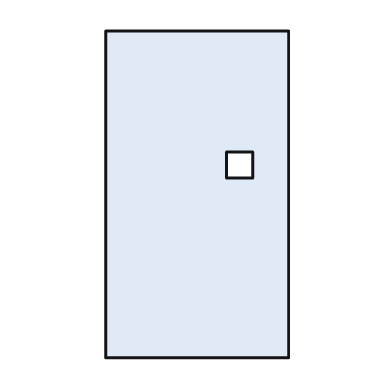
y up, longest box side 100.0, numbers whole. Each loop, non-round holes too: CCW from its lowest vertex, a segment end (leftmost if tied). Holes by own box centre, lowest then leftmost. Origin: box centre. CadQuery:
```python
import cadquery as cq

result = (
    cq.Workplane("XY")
    .moveTo(-28.0, -50.0)
    .lineTo(28.0, -50.0)
    .lineTo(28.0, 50.0)
    .lineTo(-28.0, 50.0)
    .close()
    .moveTo(9.0, 5.0)
    .lineTo(17.0, 5.0)
    .lineTo(17.0, 13.0)
    .lineTo(9.0, 13.0)
    .close()
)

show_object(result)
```